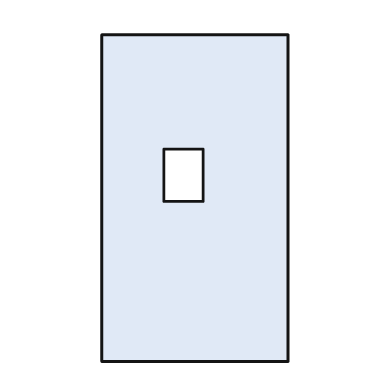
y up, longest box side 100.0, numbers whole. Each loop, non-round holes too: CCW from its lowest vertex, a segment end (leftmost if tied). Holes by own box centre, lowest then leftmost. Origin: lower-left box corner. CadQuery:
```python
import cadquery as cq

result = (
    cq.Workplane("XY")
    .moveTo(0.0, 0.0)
    .lineTo(57.0, 0.0)
    .lineTo(57.0, 100.0)
    .lineTo(0.0, 100.0)
    .close()
    .moveTo(19.0, 49.0)
    .lineTo(31.0, 49.0)
    .lineTo(31.0, 65.0)
    .lineTo(19.0, 65.0)
    .close()
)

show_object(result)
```